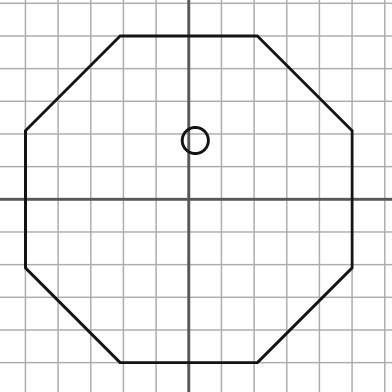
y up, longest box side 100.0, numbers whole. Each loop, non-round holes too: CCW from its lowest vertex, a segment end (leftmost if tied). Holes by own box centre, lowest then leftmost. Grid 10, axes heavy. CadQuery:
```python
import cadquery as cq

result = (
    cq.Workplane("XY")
    .moveTo(-21.0, -50.0)
    .lineTo(21.0, -50.0)
    .lineTo(50.0, -21.0)
    .lineTo(50.0, 21.0)
    .lineTo(21.0, 50.0)
    .lineTo(-21.0, 50.0)
    .lineTo(-50.0, 21.0)
    .lineTo(-50.0, -21.0)
    .close()
    .moveTo(2.0, 18.0)
    .circle(4.0)
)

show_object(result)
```